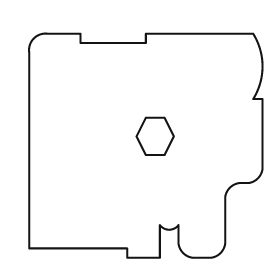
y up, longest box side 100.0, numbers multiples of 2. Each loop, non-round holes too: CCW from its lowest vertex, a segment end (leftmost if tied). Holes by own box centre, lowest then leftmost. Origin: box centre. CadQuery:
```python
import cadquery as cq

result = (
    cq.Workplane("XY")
    .moveTo(-8.0, -48.0)
    .lineTo(6.0, -48.0)
    .lineTo(6.0, -34.0)
    .threePointArc((10.0, -36.0), (14.0, -34.0))
    .lineTo(14.0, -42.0)
    .threePointArc((16.0, -46.0), (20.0, -48.0))
    .lineTo(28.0, -48.0)
    .threePointArc((32.0, -46.0), (34.0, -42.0))
    .lineTo(34.0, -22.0)
    .threePointArc((36.0, -18.0), (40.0, -16.0))
    .lineTo(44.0, -16.0)
    .threePointArc((48.0, -14.0), (50.0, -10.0))
    .lineTo(50.0, 20.0)
    .lineTo(46.0, 20.0)
    .threePointArc((50.0, 34.0), (46.0, 48.0))
    .lineTo(0.0, 48.0)
    .lineTo(0.0, 44.0)
    .lineTo(-28.0, 44.0)
    .lineTo(-28.0, 48.0)
    .lineTo(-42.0, 48.0)
    .threePointArc((-48.0, 46.0), (-50.0, 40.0))
    .lineTo(-50.0, -44.0)
    .lineTo(-8.0, -44.0)
    .close()
    .moveTo(0.0, -4.0)
    .lineTo(8.0, -4.0)
    .lineTo(12.0, 4.0)
    .lineTo(8.0, 12.0)
    .lineTo(0.0, 12.0)
    .lineTo(-4.0, 4.0)
    .close()
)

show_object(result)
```